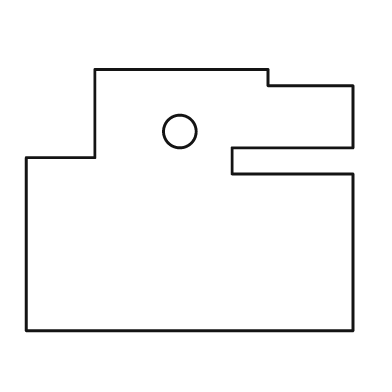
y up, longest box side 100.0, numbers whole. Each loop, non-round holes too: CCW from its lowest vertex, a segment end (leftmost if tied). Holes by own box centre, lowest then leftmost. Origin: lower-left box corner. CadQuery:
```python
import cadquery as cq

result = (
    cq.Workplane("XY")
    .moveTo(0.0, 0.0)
    .lineTo(100.0, 0.0)
    .lineTo(100.0, 48.0)
    .lineTo(63.0, 48.0)
    .lineTo(63.0, 56.0)
    .lineTo(100.0, 56.0)
    .lineTo(100.0, 75.0)
    .lineTo(74.0, 75.0)
    .lineTo(74.0, 80.0)
    .lineTo(21.0, 80.0)
    .lineTo(21.0, 53.0)
    .lineTo(0.0, 53.0)
    .close()
    .moveTo(47.0, 61.0)
    .circle(5.0)
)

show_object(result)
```